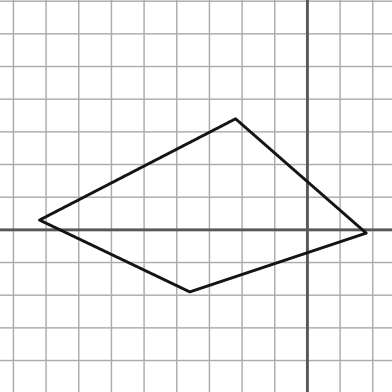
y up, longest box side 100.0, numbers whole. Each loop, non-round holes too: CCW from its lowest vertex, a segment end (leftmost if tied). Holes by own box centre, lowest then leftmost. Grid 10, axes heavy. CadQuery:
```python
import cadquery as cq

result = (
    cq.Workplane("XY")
    .moveTo(-36.0, -19.0)
    .lineTo(18.0, -1.0)
    .lineTo(-22.0, 34.0)
    .lineTo(-82.0, 3.0)
    .close()
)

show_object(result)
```